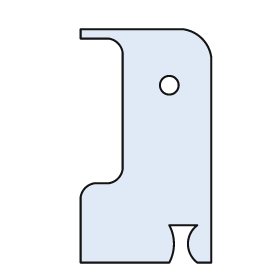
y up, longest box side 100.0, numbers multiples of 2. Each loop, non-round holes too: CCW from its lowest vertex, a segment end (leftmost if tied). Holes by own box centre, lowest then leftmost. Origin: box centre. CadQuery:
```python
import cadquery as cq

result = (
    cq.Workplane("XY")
    .moveTo(-28.0, -50.0)
    .lineTo(10.0, -50.0)
    .threePointArc((12.0, -42.0), (10.0, -34.0))
    .lineTo(22.0, -34.0)
    .threePointArc((18.0, -42.0), (22.0, -50.0))
    .lineTo(28.0, -50.0)
    .lineTo(28.0, 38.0)
    .threePointArc((24.0, 46.0), (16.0, 50.0))
    .lineTo(-28.0, 50.0)
    .lineTo(-28.0, 46.0)
    .lineTo(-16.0, 46.0)
    .threePointArc((-12.0, 44.0), (-10.0, 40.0))
    .lineTo(-10.0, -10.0)
    .threePointArc((-12.0, -14.0), (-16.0, -16.0))
    .lineTo(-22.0, -16.0)
    .threePointArc((-26.0, -18.0), (-28.0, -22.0))
    .close()
    .moveTo(10.0, 26.0)
    .circle(4.0)
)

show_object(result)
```